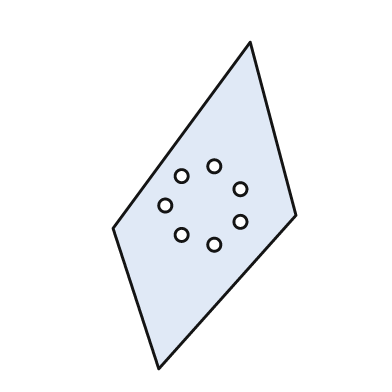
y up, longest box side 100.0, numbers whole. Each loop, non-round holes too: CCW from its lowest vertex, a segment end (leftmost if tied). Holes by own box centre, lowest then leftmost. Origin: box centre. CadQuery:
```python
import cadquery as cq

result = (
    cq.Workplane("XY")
    .moveTo(-14.0, -50.0)
    .lineTo(28.0, -3.0)
    .lineTo(14.0, 50.0)
    .lineTo(-28.0, -7.0)
    .close()
    .moveTo(3.0, -12.0)
    .circle(2.0)
    .moveTo(-7.0, -9.0)
    .circle(2.0)
    .moveTo(11.0, -5.0)
    .circle(2.0)
    .moveTo(-12.0, 0.0)
    .circle(2.0)
    .moveTo(11.0, 5.0)
    .circle(2.0)
    .moveTo(-7.0, 9.0)
    .circle(2.0)
    .moveTo(3.0, 12.0)
    .circle(2.0)
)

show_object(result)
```